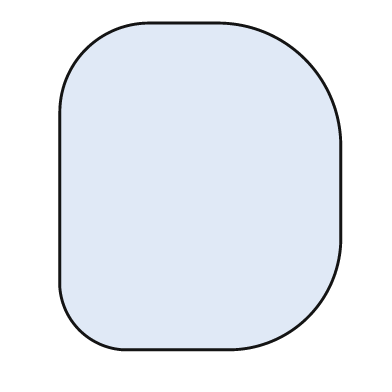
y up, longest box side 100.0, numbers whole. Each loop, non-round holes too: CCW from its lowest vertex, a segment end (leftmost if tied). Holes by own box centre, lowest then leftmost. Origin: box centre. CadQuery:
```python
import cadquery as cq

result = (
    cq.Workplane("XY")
    .moveTo(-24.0, -50.0)
    .lineTo(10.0, -50.0)
    .threePointArc((33.0, -40.0), (43.0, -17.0))
    .lineTo(43.0, 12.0)
    .threePointArc((32.0, 39.0), (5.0, 50.0))
    .lineTo(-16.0, 50.0)
    .threePointArc((-35.0, 42.0), (-43.0, 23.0))
    .lineTo(-43.0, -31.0)
    .threePointArc((-37.0, -44.0), (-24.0, -50.0))
    .close()
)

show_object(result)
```